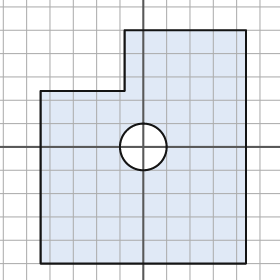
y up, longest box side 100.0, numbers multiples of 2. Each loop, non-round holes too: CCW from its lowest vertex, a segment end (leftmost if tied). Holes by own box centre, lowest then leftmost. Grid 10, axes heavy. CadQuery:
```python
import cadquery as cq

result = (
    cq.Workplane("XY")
    .moveTo(-44.0, -50.0)
    .lineTo(44.0, -50.0)
    .lineTo(44.0, 50.0)
    .lineTo(-8.0, 50.0)
    .lineTo(-8.0, 24.0)
    .lineTo(-44.0, 24.0)
    .close()
    .moveTo(0.0, 0.0)
    .circle(10.0)
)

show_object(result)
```